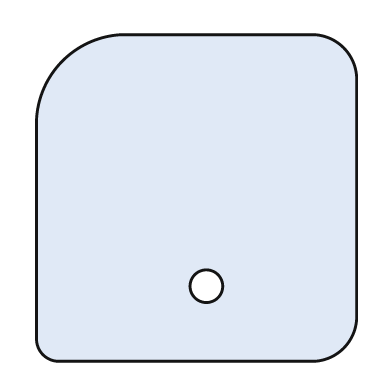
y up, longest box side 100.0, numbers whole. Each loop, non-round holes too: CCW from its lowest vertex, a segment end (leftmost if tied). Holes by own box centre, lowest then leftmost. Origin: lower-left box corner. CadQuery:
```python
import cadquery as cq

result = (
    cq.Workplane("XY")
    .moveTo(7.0, 0.0)
    .lineTo(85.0, 0.0)
    .threePointArc((94.0, 4.0), (98.0, 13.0))
    .lineTo(98.0, 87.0)
    .threePointArc((94.0, 96.0), (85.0, 100.0))
    .lineTo(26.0, 100.0)
    .threePointArc((8.0, 92.0), (0.0, 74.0))
    .lineTo(0.0, 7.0)
    .threePointArc((2.0, 2.0), (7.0, 0.0))
    .close()
    .moveTo(52.0, 23.0)
    .circle(5.0)
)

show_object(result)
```